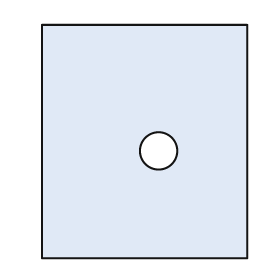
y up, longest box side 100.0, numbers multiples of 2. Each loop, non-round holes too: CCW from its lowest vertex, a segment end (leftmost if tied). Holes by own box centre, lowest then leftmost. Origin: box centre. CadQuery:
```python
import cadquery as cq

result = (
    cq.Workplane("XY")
    .moveTo(-44.0, -50.0)
    .lineTo(44.0, -50.0)
    .lineTo(44.0, 50.0)
    .lineTo(-44.0, 50.0)
    .close()
    .moveTo(6.0, -4.0)
    .circle(8.0)
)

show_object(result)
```